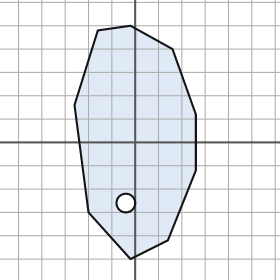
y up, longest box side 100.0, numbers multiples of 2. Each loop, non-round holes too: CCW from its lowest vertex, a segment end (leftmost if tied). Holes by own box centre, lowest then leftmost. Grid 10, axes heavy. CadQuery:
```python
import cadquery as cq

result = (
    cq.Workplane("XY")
    .moveTo(-2.0, -50.0)
    .lineTo(14.0, -42.0)
    .lineTo(26.0, -12.0)
    .lineTo(26.0, 12.0)
    .lineTo(16.0, 40.0)
    .lineTo(-2.0, 50.0)
    .lineTo(-16.0, 48.0)
    .lineTo(-26.0, 16.0)
    .lineTo(-20.0, -30.0)
    .close()
    .moveTo(-4.0, -26.0)
    .circle(4.0)
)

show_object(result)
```